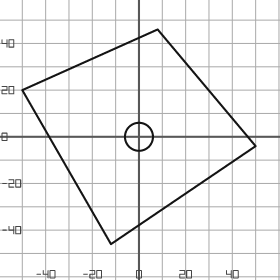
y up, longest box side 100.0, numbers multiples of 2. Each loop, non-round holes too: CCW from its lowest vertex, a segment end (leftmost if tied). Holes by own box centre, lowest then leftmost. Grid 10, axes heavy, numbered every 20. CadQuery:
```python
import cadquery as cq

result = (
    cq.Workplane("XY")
    .moveTo(-12.0, -46.0)
    .lineTo(50.0, -4.0)
    .lineTo(8.0, 46.0)
    .lineTo(-50.0, 20.0)
    .close()
    .moveTo(0.0, 0.0)
    .circle(6.0)
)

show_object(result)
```